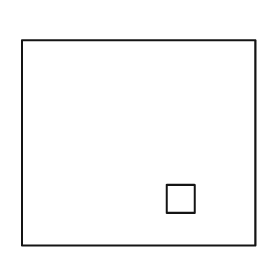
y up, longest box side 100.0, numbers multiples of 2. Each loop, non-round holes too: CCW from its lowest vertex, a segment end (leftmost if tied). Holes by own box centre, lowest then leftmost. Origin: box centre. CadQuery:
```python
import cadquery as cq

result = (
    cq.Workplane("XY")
    .moveTo(-50.0, -44.0)
    .lineTo(50.0, -44.0)
    .lineTo(50.0, 44.0)
    .lineTo(-50.0, 44.0)
    .close()
    .moveTo(12.0, -30.0)
    .lineTo(24.0, -30.0)
    .lineTo(24.0, -18.0)
    .lineTo(12.0, -18.0)
    .close()
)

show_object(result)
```